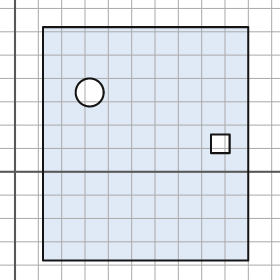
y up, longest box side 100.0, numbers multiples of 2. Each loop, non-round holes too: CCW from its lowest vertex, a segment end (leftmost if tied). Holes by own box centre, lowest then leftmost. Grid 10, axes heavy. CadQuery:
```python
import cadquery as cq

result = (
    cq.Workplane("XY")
    .moveTo(12.0, -38.0)
    .lineTo(100.0, -38.0)
    .lineTo(100.0, 62.0)
    .lineTo(12.0, 62.0)
    .close()
    .moveTo(84.0, 8.0)
    .lineTo(92.0, 8.0)
    .lineTo(92.0, 16.0)
    .lineTo(84.0, 16.0)
    .close()
    .moveTo(32.0, 34.0)
    .circle(6.0)
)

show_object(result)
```